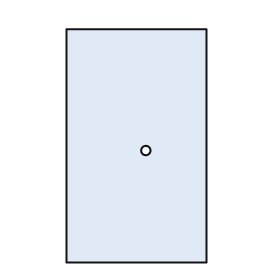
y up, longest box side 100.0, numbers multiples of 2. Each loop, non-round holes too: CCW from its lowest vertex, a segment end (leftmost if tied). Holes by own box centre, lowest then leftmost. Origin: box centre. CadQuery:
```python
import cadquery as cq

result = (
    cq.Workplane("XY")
    .moveTo(-30.0, -50.0)
    .lineTo(30.0, -50.0)
    .lineTo(30.0, 50.0)
    .lineTo(-30.0, 50.0)
    .close()
    .moveTo(4.0, -2.0)
    .circle(2.0)
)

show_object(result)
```